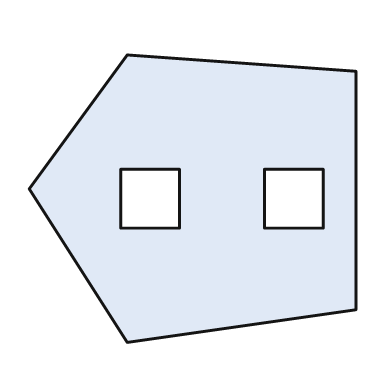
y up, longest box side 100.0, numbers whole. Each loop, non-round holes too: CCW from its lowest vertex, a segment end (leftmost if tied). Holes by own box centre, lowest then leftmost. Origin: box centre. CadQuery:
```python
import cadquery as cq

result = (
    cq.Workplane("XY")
    .moveTo(-20.0, -44.0)
    .lineTo(50.0, -34.0)
    .lineTo(50.0, 39.0)
    .lineTo(-20.0, 44.0)
    .lineTo(-50.0, 3.0)
    .close()
    .moveTo(-22.0, -9.0)
    .lineTo(-4.0, -9.0)
    .lineTo(-4.0, 9.0)
    .lineTo(-22.0, 9.0)
    .close()
    .moveTo(22.0, -9.0)
    .lineTo(40.0, -9.0)
    .lineTo(40.0, 9.0)
    .lineTo(22.0, 9.0)
    .close()
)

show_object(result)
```